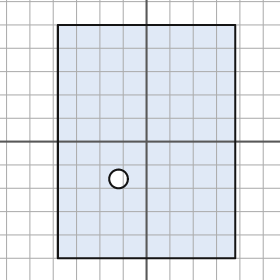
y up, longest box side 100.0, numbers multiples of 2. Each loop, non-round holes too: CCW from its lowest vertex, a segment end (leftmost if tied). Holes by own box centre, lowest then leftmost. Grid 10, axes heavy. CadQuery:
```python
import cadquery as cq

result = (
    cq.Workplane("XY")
    .moveTo(-38.0, -50.0)
    .lineTo(38.0, -50.0)
    .lineTo(38.0, 50.0)
    .lineTo(-38.0, 50.0)
    .close()
    .moveTo(-12.0, -16.0)
    .circle(4.0)
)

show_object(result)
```